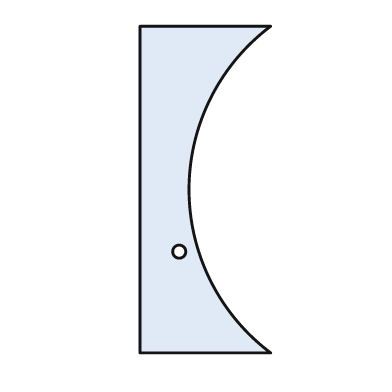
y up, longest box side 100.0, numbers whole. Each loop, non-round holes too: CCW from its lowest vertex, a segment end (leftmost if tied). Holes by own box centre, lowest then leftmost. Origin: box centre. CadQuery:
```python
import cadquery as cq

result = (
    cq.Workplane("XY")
    .moveTo(-20.0, -50.0)
    .lineTo(20.0, -50.0)
    .threePointArc((-5.0, 0.0), (20.0, 50.0))
    .lineTo(-20.0, 50.0)
    .close()
    .moveTo(-8.0, -19.0)
    .circle(2.0)
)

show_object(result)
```